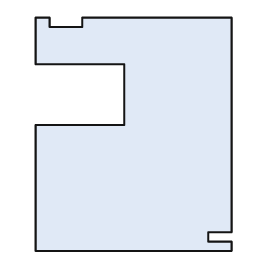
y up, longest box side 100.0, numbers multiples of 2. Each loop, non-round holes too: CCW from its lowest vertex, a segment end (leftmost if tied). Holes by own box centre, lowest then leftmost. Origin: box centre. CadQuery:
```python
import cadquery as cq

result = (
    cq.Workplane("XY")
    .moveTo(-42.0, -50.0)
    .lineTo(42.0, -50.0)
    .lineTo(42.0, -46.0)
    .lineTo(32.0, -46.0)
    .lineTo(32.0, -42.0)
    .lineTo(42.0, -42.0)
    .lineTo(42.0, 50.0)
    .lineTo(-22.0, 50.0)
    .lineTo(-22.0, 46.0)
    .lineTo(-36.0, 46.0)
    .lineTo(-36.0, 50.0)
    .lineTo(-42.0, 50.0)
    .lineTo(-42.0, 30.0)
    .lineTo(-4.0, 30.0)
    .lineTo(-4.0, 4.0)
    .lineTo(-42.0, 4.0)
    .close()
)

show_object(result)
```